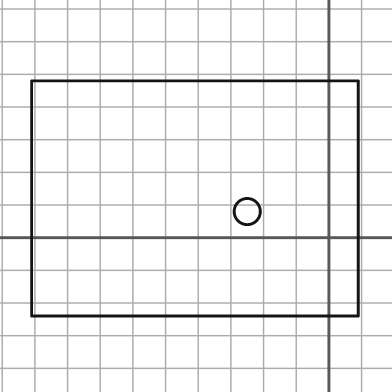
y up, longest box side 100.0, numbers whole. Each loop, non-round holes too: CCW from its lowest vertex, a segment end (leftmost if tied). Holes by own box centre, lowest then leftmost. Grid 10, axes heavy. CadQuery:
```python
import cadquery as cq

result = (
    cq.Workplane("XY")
    .moveTo(-91.0, -24.0)
    .lineTo(9.0, -24.0)
    .lineTo(9.0, 48.0)
    .lineTo(-91.0, 48.0)
    .close()
    .moveTo(-25.0, 8.0)
    .circle(4.0)
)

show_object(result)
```